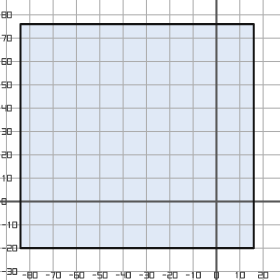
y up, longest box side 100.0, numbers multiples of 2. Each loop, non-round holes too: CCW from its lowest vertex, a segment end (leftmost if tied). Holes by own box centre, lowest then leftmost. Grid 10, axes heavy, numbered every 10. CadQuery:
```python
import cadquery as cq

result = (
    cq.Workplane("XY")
    .moveTo(-84.0, -20.0)
    .lineTo(16.0, -20.0)
    .lineTo(16.0, 76.0)
    .lineTo(-84.0, 76.0)
    .close()
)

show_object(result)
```